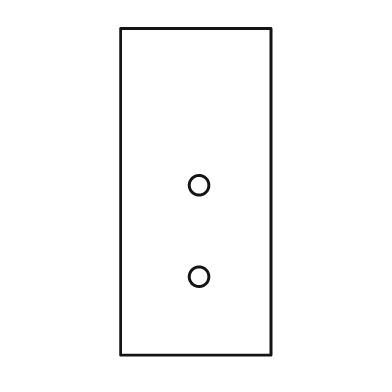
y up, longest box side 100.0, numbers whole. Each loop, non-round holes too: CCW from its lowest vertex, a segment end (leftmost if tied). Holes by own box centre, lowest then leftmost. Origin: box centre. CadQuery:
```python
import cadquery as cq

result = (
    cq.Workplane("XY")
    .moveTo(-23.0, -50.0)
    .lineTo(23.0, -50.0)
    .lineTo(23.0, 50.0)
    .lineTo(-23.0, 50.0)
    .close()
    .moveTo(1.0, -26.0)
    .circle(3.0)
    .moveTo(1.0, 2.0)
    .circle(3.0)
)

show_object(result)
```